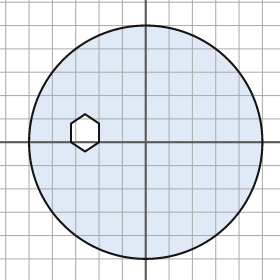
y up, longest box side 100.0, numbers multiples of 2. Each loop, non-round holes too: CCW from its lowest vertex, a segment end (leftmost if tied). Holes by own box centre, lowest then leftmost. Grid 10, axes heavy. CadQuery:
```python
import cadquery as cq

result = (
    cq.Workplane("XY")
    .moveTo(0.0, 0.0)
    .circle(50.0)
    .moveTo(-26.0, -4.0)
    .lineTo(-20.0, 0.0)
    .lineTo(-20.0, 8.0)
    .lineTo(-26.0, 12.0)
    .lineTo(-32.0, 8.0)
    .lineTo(-32.0, 0.0)
    .close()
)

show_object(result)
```